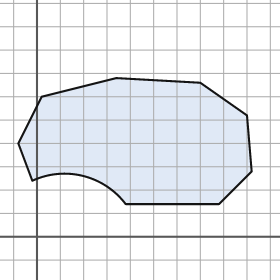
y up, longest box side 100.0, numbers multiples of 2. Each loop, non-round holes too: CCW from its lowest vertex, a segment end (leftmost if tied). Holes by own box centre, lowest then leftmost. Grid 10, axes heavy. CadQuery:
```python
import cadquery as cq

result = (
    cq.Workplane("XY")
    .moveTo(38.0, 14.0)
    .lineTo(78.0, 14.0)
    .lineTo(92.0, 28.0)
    .lineTo(90.0, 52.0)
    .lineTo(70.0, 66.0)
    .lineTo(34.0, 68.0)
    .lineTo(2.0, 60.0)
    .lineTo(-8.0, 40.0)
    .lineTo(-2.0, 24.0)
    .threePointArc((20.0, 26.0), (38.0, 14.0))
    .close()
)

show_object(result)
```